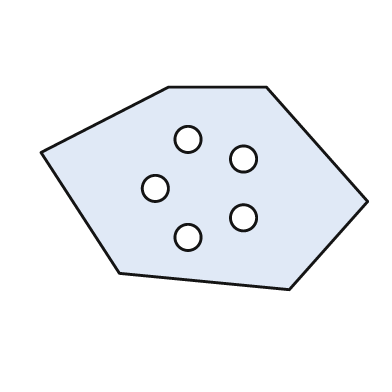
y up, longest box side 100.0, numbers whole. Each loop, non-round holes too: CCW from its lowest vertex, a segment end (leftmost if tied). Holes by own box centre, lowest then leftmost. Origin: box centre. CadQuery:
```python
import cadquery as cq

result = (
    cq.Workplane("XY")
    .moveTo(26.0, -31.0)
    .lineTo(50.0, -4.0)
    .lineTo(19.0, 31.0)
    .lineTo(-11.0, 31.0)
    .lineTo(-50.0, 11.0)
    .lineTo(-26.0, -26.0)
    .close()
    .moveTo(-5.0, -15.0)
    .circle(4.0)
    .moveTo(12.0, -9.0)
    .circle(4.0)
    .moveTo(-15.0, 0.0)
    .circle(4.0)
    .moveTo(12.0, 9.0)
    .circle(4.0)
    .moveTo(-5.0, 15.0)
    .circle(4.0)
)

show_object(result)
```